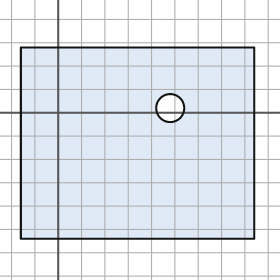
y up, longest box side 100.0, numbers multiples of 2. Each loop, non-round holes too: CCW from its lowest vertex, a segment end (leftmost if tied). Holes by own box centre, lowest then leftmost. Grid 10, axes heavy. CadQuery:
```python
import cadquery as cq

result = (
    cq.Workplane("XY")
    .moveTo(-16.0, -54.0)
    .lineTo(84.0, -54.0)
    .lineTo(84.0, 28.0)
    .lineTo(-16.0, 28.0)
    .close()
    .moveTo(48.0, 2.0)
    .circle(6.0)
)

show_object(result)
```